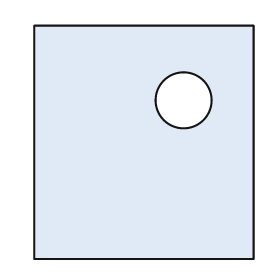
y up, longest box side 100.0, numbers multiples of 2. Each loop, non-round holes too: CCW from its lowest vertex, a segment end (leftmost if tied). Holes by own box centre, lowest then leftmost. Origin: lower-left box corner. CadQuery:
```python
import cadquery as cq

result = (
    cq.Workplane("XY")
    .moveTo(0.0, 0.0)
    .lineTo(94.0, 0.0)
    .lineTo(94.0, 100.0)
    .lineTo(0.0, 100.0)
    .close()
    .moveTo(64.0, 68.0)
    .circle(12.0)
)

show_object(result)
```